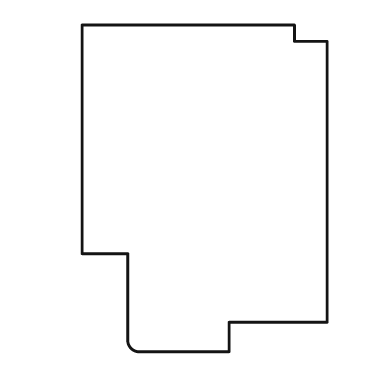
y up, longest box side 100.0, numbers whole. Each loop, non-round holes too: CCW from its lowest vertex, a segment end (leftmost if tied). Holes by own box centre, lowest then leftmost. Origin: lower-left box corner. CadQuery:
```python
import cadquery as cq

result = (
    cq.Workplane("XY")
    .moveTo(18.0, 0.0)
    .lineTo(45.0, 0.0)
    .lineTo(45.0, 9.0)
    .lineTo(75.0, 9.0)
    .lineTo(75.0, 95.0)
    .lineTo(65.0, 95.0)
    .lineTo(65.0, 100.0)
    .lineTo(0.0, 100.0)
    .lineTo(0.0, 30.0)
    .lineTo(14.0, 30.0)
    .lineTo(14.0, 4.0)
    .threePointArc((15.0, 1.0), (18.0, 0.0))
    .close()
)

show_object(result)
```